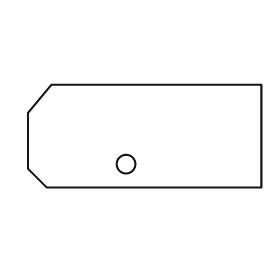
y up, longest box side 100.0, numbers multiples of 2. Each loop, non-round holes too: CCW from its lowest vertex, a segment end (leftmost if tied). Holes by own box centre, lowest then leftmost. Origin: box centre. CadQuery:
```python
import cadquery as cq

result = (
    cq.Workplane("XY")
    .moveTo(-42.0, -22.0)
    .lineTo(50.0, -22.0)
    .lineTo(50.0, 22.0)
    .lineTo(-40.0, 22.0)
    .lineTo(-50.0, 10.0)
    .lineTo(-50.0, -14.0)
    .close()
    .moveTo(-8.0, -12.0)
    .circle(4.0)
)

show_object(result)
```